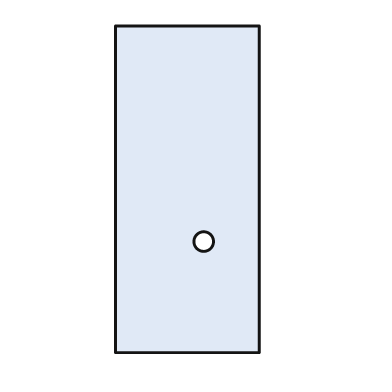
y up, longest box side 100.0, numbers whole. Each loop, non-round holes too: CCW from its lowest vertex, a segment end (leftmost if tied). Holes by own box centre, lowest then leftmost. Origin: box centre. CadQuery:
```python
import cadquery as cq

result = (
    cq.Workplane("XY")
    .moveTo(-22.0, -50.0)
    .lineTo(22.0, -50.0)
    .lineTo(22.0, 50.0)
    .lineTo(-22.0, 50.0)
    .close()
    .moveTo(5.0, -16.0)
    .circle(3.0)
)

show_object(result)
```